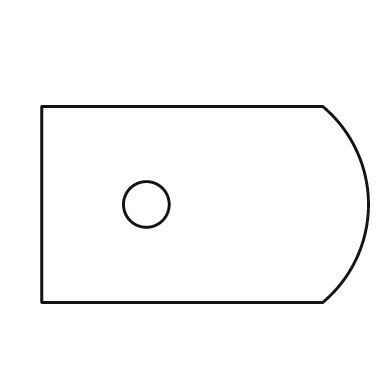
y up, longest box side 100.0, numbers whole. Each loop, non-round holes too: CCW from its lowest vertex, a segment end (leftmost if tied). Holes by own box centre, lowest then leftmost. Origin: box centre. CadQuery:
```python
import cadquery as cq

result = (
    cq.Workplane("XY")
    .moveTo(-50.0, -30.0)
    .lineTo(36.0, -30.0)
    .threePointArc((50.0, 0.0), (36.0, 30.0))
    .lineTo(-50.0, 30.0)
    .close()
    .moveTo(-18.0, 0.0)
    .circle(7.0)
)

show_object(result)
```